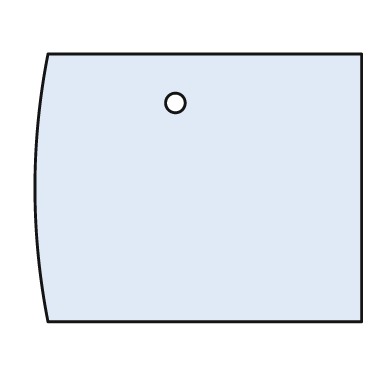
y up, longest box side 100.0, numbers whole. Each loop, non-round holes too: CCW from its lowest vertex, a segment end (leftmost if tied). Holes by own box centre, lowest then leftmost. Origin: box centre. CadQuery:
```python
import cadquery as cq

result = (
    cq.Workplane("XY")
    .moveTo(-46.0, -41.0)
    .lineTo(50.0, -41.0)
    .lineTo(50.0, 41.0)
    .lineTo(-46.0, 41.0)
    .threePointArc((-50.0, 0.0), (-46.0, -41.0))
    .close()
    .moveTo(-7.0, 26.0)
    .circle(3.0)
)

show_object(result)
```